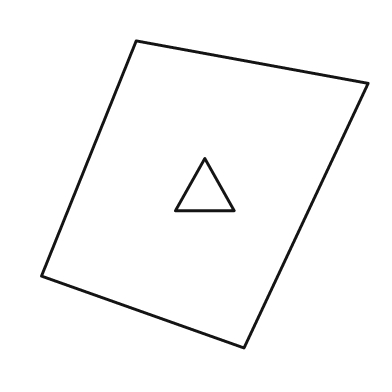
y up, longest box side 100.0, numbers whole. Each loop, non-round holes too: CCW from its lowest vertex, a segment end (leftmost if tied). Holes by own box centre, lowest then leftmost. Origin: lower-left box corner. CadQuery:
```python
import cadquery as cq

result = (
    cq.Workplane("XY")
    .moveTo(62.0, 0.0)
    .lineTo(100.0, 81.0)
    .lineTo(29.0, 94.0)
    .lineTo(0.0, 22.0)
    .close()
    .moveTo(41.0, 42.0)
    .lineTo(59.0, 42.0)
    .lineTo(50.0, 58.0)
    .close()
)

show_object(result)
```